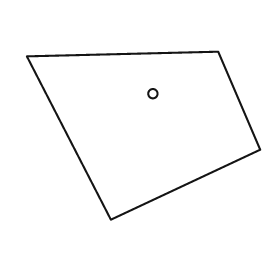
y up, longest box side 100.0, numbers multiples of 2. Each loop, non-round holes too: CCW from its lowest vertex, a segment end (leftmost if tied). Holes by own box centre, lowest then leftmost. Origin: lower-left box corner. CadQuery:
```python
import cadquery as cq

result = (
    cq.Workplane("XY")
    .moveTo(36.0, 0.0)
    .lineTo(100.0, 30.0)
    .lineTo(82.0, 72.0)
    .lineTo(0.0, 70.0)
    .close()
    .moveTo(54.0, 54.0)
    .circle(2.0)
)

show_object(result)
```